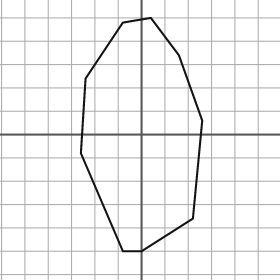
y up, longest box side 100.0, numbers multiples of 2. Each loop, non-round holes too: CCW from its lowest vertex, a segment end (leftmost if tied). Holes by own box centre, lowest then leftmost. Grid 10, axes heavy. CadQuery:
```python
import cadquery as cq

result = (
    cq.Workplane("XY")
    .moveTo(-8.0, -50.0)
    .lineTo(0.0, -50.0)
    .lineTo(22.0, -36.0)
    .lineTo(26.0, 6.0)
    .lineTo(16.0, 34.0)
    .lineTo(4.0, 50.0)
    .lineTo(-8.0, 48.0)
    .lineTo(-24.0, 24.0)
    .lineTo(-26.0, -8.0)
    .close()
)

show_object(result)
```